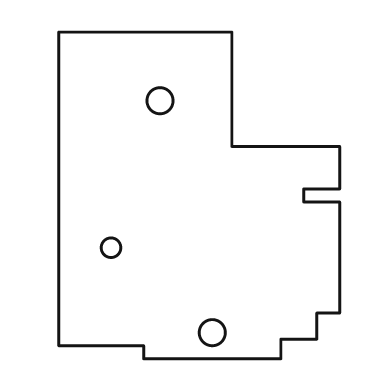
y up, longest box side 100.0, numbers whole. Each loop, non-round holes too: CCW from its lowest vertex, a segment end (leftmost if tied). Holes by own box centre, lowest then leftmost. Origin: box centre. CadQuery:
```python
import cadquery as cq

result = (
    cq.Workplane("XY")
    .moveTo(-17.0, -50.0)
    .lineTo(25.0, -50.0)
    .lineTo(25.0, -44.0)
    .lineTo(36.0, -44.0)
    .lineTo(36.0, -36.0)
    .lineTo(43.0, -36.0)
    .lineTo(43.0, -2.0)
    .lineTo(32.0, -2.0)
    .lineTo(32.0, 2.0)
    .lineTo(43.0, 2.0)
    .lineTo(43.0, 15.0)
    .lineTo(10.0, 15.0)
    .lineTo(10.0, 50.0)
    .lineTo(-43.0, 50.0)
    .lineTo(-43.0, -46.0)
    .lineTo(-17.0, -46.0)
    .close()
    .moveTo(4.0, -42.0)
    .circle(4.0)
    .moveTo(-27.0, -16.0)
    .circle(3.0)
    .moveTo(-12.0, 29.0)
    .circle(4.0)
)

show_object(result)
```